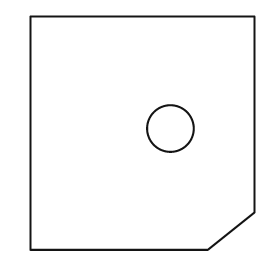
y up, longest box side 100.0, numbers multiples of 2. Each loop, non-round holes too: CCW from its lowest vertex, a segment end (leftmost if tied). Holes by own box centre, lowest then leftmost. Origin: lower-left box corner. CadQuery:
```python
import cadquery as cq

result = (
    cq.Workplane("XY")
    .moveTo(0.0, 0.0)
    .lineTo(76.0, 0.0)
    .lineTo(96.0, 16.0)
    .lineTo(96.0, 100.0)
    .lineTo(0.0, 100.0)
    .close()
    .moveTo(60.0, 52.0)
    .circle(10.0)
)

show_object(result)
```